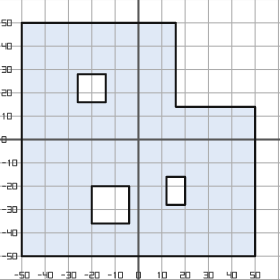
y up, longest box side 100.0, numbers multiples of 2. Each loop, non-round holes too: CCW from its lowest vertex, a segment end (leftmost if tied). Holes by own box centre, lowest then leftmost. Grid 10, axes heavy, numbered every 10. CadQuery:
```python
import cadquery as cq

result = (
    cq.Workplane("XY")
    .moveTo(-50.0, -50.0)
    .lineTo(50.0, -50.0)
    .lineTo(50.0, 14.0)
    .lineTo(16.0, 14.0)
    .lineTo(16.0, 50.0)
    .lineTo(-50.0, 50.0)
    .close()
    .moveTo(-20.0, -36.0)
    .lineTo(-4.0, -36.0)
    .lineTo(-4.0, -20.0)
    .lineTo(-20.0, -20.0)
    .close()
    .moveTo(12.0, -28.0)
    .lineTo(20.0, -28.0)
    .lineTo(20.0, -16.0)
    .lineTo(12.0, -16.0)
    .close()
    .moveTo(-26.0, 16.0)
    .lineTo(-14.0, 16.0)
    .lineTo(-14.0, 28.0)
    .lineTo(-26.0, 28.0)
    .close()
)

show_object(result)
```